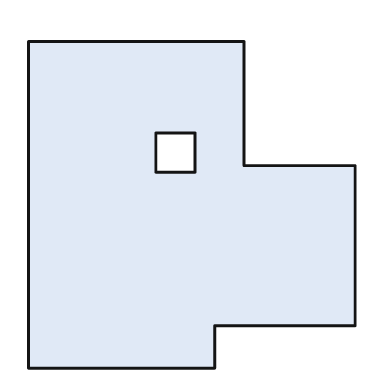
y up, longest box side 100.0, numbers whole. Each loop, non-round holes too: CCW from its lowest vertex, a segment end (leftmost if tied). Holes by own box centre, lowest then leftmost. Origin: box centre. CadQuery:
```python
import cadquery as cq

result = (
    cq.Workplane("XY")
    .moveTo(-50.0, -50.0)
    .lineTo(7.0, -50.0)
    .lineTo(7.0, -37.0)
    .lineTo(50.0, -37.0)
    .lineTo(50.0, 12.0)
    .lineTo(16.0, 12.0)
    .lineTo(16.0, 50.0)
    .lineTo(-50.0, 50.0)
    .close()
    .moveTo(-11.0, 10.0)
    .lineTo(1.0, 10.0)
    .lineTo(1.0, 22.0)
    .lineTo(-11.0, 22.0)
    .close()
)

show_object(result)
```